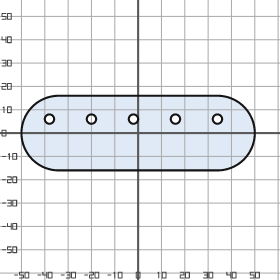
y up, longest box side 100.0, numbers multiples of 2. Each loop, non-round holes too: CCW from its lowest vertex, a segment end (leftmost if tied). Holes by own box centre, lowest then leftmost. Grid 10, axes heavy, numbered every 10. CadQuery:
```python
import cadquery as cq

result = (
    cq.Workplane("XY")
    .moveTo(-34.0, -16.0)
    .lineTo(34.0, -16.0)
    .threePointArc((50.0, 0.0), (34.0, 16.0))
    .lineTo(-34.0, 16.0)
    .threePointArc((-50.0, 0.0), (-34.0, -16.0))
    .close()
    .moveTo(-38.0, 6.0)
    .circle(2.0)
    .moveTo(-20.0, 6.0)
    .circle(2.0)
    .moveTo(-2.0, 6.0)
    .circle(2.0)
    .moveTo(16.0, 6.0)
    .circle(2.0)
    .moveTo(34.0, 6.0)
    .circle(2.0)
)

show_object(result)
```